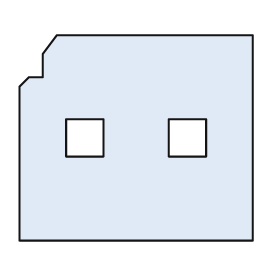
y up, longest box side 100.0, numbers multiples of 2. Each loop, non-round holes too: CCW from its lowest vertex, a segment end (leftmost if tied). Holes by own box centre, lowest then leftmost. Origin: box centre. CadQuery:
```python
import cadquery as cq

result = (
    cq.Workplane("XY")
    .moveTo(-50.0, -44.0)
    .lineTo(50.0, -44.0)
    .lineTo(50.0, 44.0)
    .lineTo(-34.0, 44.0)
    .lineTo(-40.0, 36.0)
    .lineTo(-40.0, 26.0)
    .lineTo(-46.0, 26.0)
    .lineTo(-50.0, 22.0)
    .close()
    .moveTo(-30.0, -8.0)
    .lineTo(-14.0, -8.0)
    .lineTo(-14.0, 8.0)
    .lineTo(-30.0, 8.0)
    .close()
    .moveTo(14.0, -8.0)
    .lineTo(30.0, -8.0)
    .lineTo(30.0, 8.0)
    .lineTo(14.0, 8.0)
    .close()
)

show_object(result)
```